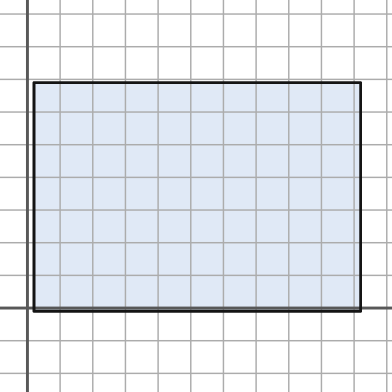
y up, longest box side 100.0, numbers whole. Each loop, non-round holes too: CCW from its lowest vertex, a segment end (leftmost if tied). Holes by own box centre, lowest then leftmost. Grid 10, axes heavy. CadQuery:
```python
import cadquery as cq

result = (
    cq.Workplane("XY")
    .moveTo(2.0, -1.0)
    .lineTo(102.0, -1.0)
    .lineTo(102.0, 69.0)
    .lineTo(2.0, 69.0)
    .close()
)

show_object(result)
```